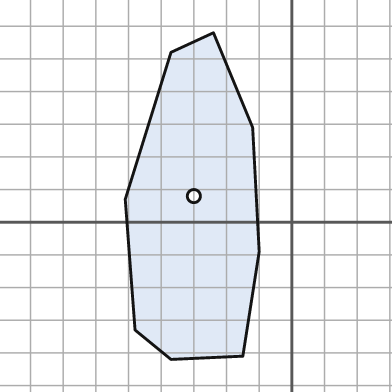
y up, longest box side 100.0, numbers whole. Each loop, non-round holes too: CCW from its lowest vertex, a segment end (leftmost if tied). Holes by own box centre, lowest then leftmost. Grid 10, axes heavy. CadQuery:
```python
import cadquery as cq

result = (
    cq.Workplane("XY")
    .moveTo(-37.0, -42.0)
    .lineTo(-15.0, -41.0)
    .lineTo(-10.0, -9.0)
    .lineTo(-12.0, 29.0)
    .lineTo(-24.0, 58.0)
    .lineTo(-37.0, 52.0)
    .lineTo(-51.0, 7.0)
    .lineTo(-48.0, -33.0)
    .close()
    .moveTo(-30.0, 8.0)
    .circle(2.0)
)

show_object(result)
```